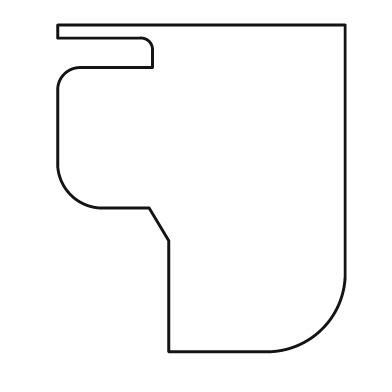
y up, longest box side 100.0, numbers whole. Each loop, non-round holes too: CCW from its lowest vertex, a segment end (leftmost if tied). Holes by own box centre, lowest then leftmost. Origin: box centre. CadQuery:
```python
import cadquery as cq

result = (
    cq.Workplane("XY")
    .moveTo(-10.0, -50.0)
    .lineTo(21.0, -50.0)
    .threePointArc((37.0, -43.0), (44.0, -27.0))
    .lineTo(44.0, 50.0)
    .lineTo(-44.0, 50.0)
    .lineTo(-44.0, 46.0)
    .lineTo(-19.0, 46.0)
    .threePointArc((-16.0, 45.0), (-15.0, 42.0))
    .lineTo(-15.0, 37.0)
    .lineTo(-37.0, 37.0)
    .threePointArc((-42.0, 35.0), (-44.0, 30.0))
    .lineTo(-44.0, 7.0)
    .threePointArc((-40.0, -2.0), (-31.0, -6.0))
    .lineTo(-16.0, -6.0)
    .lineTo(-10.0, -16.0)
    .close()
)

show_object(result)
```